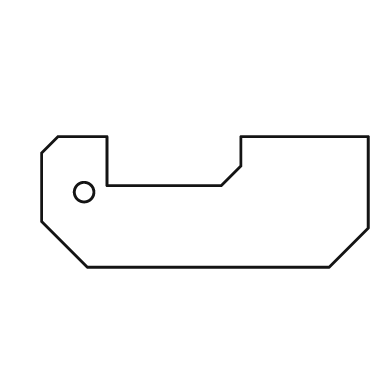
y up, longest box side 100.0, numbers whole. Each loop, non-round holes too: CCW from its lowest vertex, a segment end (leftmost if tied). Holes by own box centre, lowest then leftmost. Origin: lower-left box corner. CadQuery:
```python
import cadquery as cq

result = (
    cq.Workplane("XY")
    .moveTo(14.0, 0.0)
    .lineTo(88.0, 0.0)
    .lineTo(100.0, 12.0)
    .lineTo(100.0, 40.0)
    .lineTo(61.0, 40.0)
    .lineTo(61.0, 31.0)
    .lineTo(55.0, 25.0)
    .lineTo(20.0, 25.0)
    .lineTo(20.0, 40.0)
    .lineTo(5.0, 40.0)
    .lineTo(0.0, 35.0)
    .lineTo(0.0, 14.0)
    .close()
    .moveTo(13.0, 23.0)
    .circle(3.0)
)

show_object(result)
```